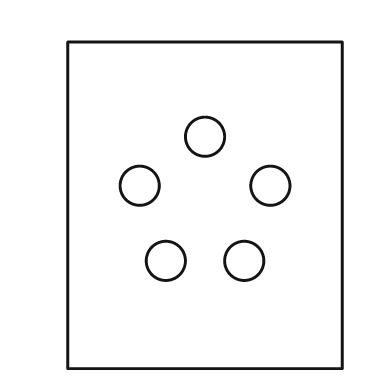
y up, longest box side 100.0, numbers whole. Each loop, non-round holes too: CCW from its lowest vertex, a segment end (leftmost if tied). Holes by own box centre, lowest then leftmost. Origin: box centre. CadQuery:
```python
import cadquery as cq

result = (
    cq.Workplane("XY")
    .moveTo(-42.0, -50.0)
    .lineTo(42.0, -50.0)
    .lineTo(42.0, 50.0)
    .lineTo(-42.0, 50.0)
    .close()
    .moveTo(-12.0, -17.0)
    .circle(6.0)
    .moveTo(12.0, -17.0)
    .circle(6.0)
    .moveTo(-20.0, 6.0)
    .circle(6.0)
    .moveTo(20.0, 6.0)
    .circle(6.0)
    .moveTo(0.0, 21.0)
    .circle(6.0)
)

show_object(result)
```